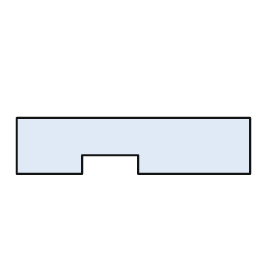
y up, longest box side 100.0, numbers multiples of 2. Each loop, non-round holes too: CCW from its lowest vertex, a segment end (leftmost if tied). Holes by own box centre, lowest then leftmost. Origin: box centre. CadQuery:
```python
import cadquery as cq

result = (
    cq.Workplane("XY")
    .moveTo(-50.0, -12.0)
    .lineTo(-22.0, -12.0)
    .lineTo(-22.0, -4.0)
    .lineTo(2.0, -4.0)
    .lineTo(2.0, -12.0)
    .lineTo(50.0, -12.0)
    .lineTo(50.0, 12.0)
    .lineTo(-50.0, 12.0)
    .close()
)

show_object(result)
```